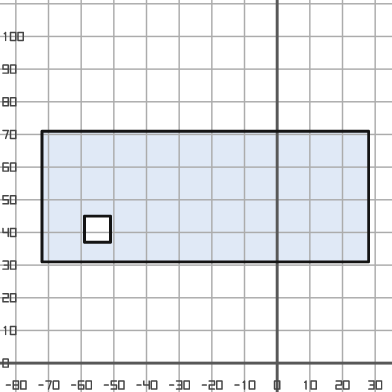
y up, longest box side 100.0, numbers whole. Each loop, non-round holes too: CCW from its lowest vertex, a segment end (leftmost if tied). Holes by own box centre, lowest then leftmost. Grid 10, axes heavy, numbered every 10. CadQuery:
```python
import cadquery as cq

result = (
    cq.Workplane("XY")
    .moveTo(-72.0, 31.0)
    .lineTo(28.0, 31.0)
    .lineTo(28.0, 71.0)
    .lineTo(-72.0, 71.0)
    .close()
    .moveTo(-59.0, 37.0)
    .lineTo(-51.0, 37.0)
    .lineTo(-51.0, 45.0)
    .lineTo(-59.0, 45.0)
    .close()
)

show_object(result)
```